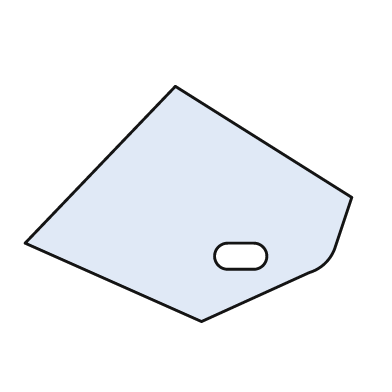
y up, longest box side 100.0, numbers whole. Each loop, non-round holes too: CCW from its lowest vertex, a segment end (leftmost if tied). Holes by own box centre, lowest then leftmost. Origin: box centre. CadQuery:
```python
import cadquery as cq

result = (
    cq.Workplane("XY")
    .moveTo(4.0, -36.0)
    .lineTo(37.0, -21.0)
    .threePointArc((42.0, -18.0), (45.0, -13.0))
    .lineTo(50.0, 2.0)
    .lineTo(-4.0, 36.0)
    .lineTo(-50.0, -12.0)
    .close()
    .moveTo(12.0, -20.0)
    .lineTo(20.0, -20.0)
    .threePointArc((24.0, -16.0), (20.0, -12.0))
    .lineTo(12.0, -12.0)
    .threePointArc((8.0, -16.0), (12.0, -20.0))
    .close()
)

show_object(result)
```